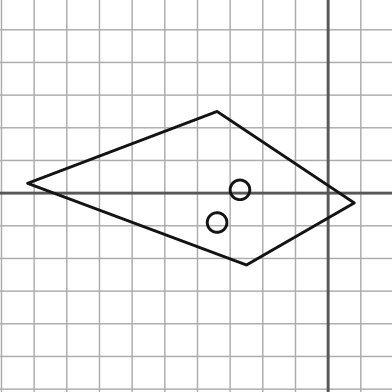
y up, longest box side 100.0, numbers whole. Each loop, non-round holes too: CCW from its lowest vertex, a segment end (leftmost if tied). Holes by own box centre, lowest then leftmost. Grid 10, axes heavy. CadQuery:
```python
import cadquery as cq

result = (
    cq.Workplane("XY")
    .moveTo(-25.0, -22.0)
    .lineTo(8.0, -3.0)
    .lineTo(-34.0, 25.0)
    .lineTo(-92.0, 3.0)
    .close()
    .moveTo(-34.0, -9.0)
    .circle(3.0)
    .moveTo(-27.0, 1.0)
    .circle(3.0)
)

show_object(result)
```